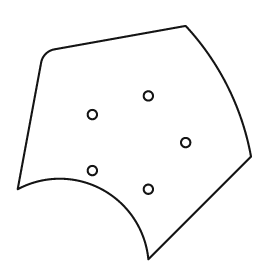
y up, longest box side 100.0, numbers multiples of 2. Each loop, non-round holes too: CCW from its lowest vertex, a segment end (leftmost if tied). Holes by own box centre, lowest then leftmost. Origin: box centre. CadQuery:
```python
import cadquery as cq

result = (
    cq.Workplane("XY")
    .moveTo(6.0, -50.0)
    .lineTo(50.0, -6.0)
    .threePointArc((40.0, 24.0), (22.0, 50.0))
    .lineTo(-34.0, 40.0)
    .threePointArc((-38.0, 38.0), (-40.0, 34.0))
    .lineTo(-50.0, -20.0)
    .threePointArc((-14.0, -20.0), (6.0, -50.0))
    .close()
    .moveTo(6.0, -20.0)
    .circle(2.0)
    .moveTo(-18.0, -12.0)
    .circle(2.0)
    .moveTo(22.0, 0.0)
    .circle(2.0)
    .moveTo(-18.0, 12.0)
    .circle(2.0)
    .moveTo(6.0, 20.0)
    .circle(2.0)
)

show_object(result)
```